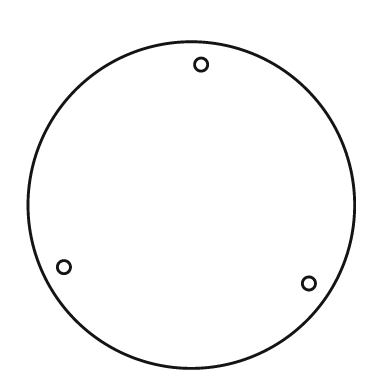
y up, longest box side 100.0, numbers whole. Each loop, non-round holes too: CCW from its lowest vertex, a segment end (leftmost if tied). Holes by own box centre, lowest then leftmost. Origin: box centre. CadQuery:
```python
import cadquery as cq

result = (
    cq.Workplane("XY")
    .moveTo(0.0, 0.0)
    .circle(50.0)
    .moveTo(36.0, -24.0)
    .circle(2.0)
    .moveTo(-39.0, -19.0)
    .circle(2.0)
    .moveTo(3.0, 43.0)
    .circle(2.0)
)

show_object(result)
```